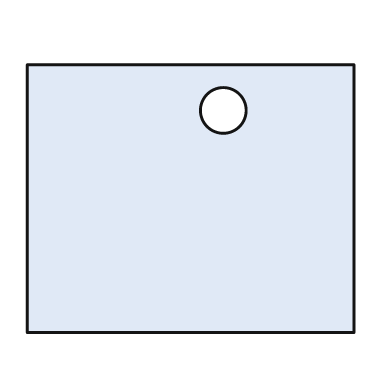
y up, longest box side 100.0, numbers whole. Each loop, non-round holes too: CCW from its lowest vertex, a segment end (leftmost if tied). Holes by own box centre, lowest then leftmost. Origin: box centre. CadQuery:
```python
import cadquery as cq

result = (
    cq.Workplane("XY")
    .moveTo(-50.0, -41.0)
    .lineTo(50.0, -41.0)
    .lineTo(50.0, 41.0)
    .lineTo(-50.0, 41.0)
    .close()
    .moveTo(10.0, 27.0)
    .circle(7.0)
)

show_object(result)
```